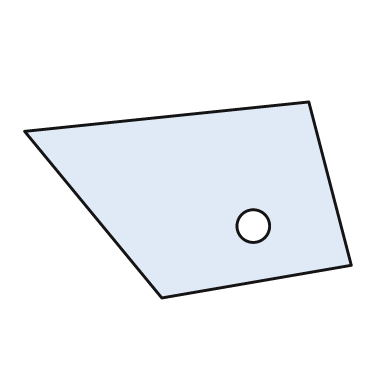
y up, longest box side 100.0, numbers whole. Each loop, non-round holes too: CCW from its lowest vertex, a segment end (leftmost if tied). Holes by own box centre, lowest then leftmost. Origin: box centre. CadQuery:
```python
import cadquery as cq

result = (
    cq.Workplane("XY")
    .moveTo(-8.0, -30.0)
    .lineTo(50.0, -20.0)
    .lineTo(37.0, 30.0)
    .lineTo(-50.0, 21.0)
    .close()
    .moveTo(20.0, -8.0)
    .circle(5.0)
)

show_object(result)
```